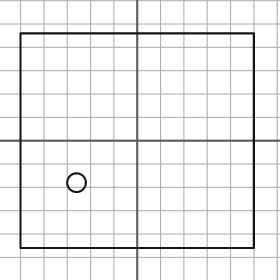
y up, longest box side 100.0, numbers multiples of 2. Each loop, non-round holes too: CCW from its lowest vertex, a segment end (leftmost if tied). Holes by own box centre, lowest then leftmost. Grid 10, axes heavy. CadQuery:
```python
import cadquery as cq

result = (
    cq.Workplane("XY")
    .moveTo(-50.0, -46.0)
    .lineTo(50.0, -46.0)
    .lineTo(50.0, 46.0)
    .lineTo(-50.0, 46.0)
    .close()
    .moveTo(-26.0, -18.0)
    .circle(4.0)
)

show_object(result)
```